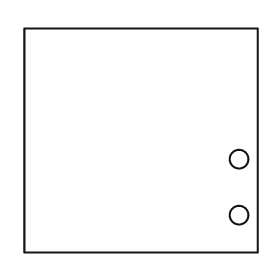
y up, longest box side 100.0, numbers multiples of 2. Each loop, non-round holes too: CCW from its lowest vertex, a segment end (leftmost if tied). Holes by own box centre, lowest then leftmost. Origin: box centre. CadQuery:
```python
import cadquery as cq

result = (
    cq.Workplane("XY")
    .moveTo(-50.0, -48.0)
    .lineTo(50.0, -48.0)
    .lineTo(50.0, 48.0)
    .lineTo(-50.0, 48.0)
    .close()
    .moveTo(42.0, -32.0)
    .circle(4.0)
    .moveTo(42.0, -8.0)
    .circle(4.0)
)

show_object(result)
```